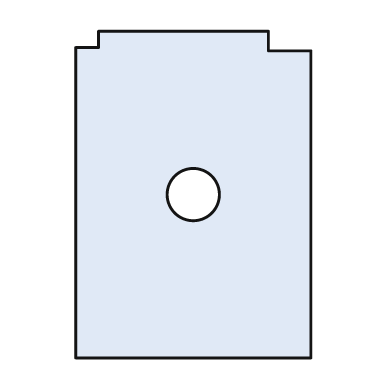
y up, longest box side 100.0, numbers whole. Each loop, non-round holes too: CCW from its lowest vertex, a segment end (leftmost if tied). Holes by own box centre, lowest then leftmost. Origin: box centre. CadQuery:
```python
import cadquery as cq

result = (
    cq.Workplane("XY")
    .moveTo(-36.0, -50.0)
    .lineTo(36.0, -50.0)
    .lineTo(36.0, 44.0)
    .lineTo(23.0, 44.0)
    .lineTo(23.0, 50.0)
    .lineTo(-29.0, 50.0)
    .lineTo(-29.0, 45.0)
    .lineTo(-36.0, 45.0)
    .close()
    .moveTo(0.0, 0.0)
    .circle(8.0)
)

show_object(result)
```